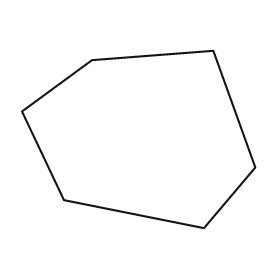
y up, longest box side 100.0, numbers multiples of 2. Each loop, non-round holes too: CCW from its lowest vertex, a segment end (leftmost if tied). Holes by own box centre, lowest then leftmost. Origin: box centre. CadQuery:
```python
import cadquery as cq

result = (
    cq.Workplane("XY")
    .moveTo(28.0, -38.0)
    .lineTo(50.0, -12.0)
    .lineTo(32.0, 38.0)
    .lineTo(-20.0, 34.0)
    .lineTo(-50.0, 12.0)
    .lineTo(-32.0, -26.0)
    .close()
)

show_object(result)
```